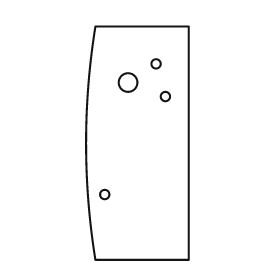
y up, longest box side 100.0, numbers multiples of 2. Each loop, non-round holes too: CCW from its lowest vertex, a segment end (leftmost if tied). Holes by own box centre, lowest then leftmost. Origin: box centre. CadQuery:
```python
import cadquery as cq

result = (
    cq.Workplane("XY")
    .moveTo(-18.0, -50.0)
    .lineTo(22.0, -50.0)
    .lineTo(22.0, 50.0)
    .lineTo(-18.0, 50.0)
    .threePointArc((-22.0, 0.0), (-18.0, -50.0))
    .close()
    .moveTo(-14.0, -22.0)
    .circle(2.0)
    .moveTo(12.0, 20.0)
    .circle(2.0)
    .moveTo(-4.0, 26.0)
    .circle(4.0)
    .moveTo(8.0, 34.0)
    .circle(2.0)
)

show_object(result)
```